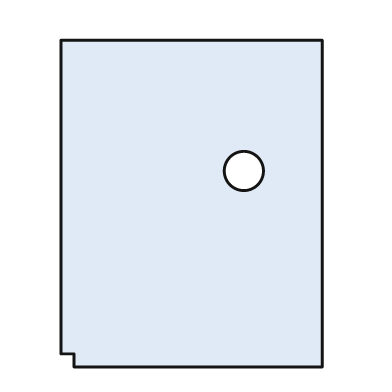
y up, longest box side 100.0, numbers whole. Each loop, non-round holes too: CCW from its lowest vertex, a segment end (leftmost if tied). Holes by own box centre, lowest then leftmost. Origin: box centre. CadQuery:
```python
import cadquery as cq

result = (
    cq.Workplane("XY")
    .moveTo(-36.0, -50.0)
    .lineTo(40.0, -50.0)
    .lineTo(40.0, 50.0)
    .lineTo(-40.0, 50.0)
    .lineTo(-40.0, -46.0)
    .lineTo(-36.0, -46.0)
    .close()
    .moveTo(16.0, 10.0)
    .circle(6.0)
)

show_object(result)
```